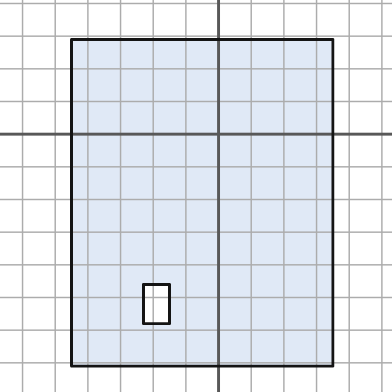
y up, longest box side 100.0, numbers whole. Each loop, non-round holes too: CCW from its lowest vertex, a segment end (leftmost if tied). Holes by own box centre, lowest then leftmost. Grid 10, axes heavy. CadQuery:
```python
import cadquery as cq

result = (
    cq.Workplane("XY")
    .moveTo(-45.0, -71.0)
    .lineTo(35.0, -71.0)
    .lineTo(35.0, 29.0)
    .lineTo(-45.0, 29.0)
    .close()
    .moveTo(-23.0, -58.0)
    .lineTo(-15.0, -58.0)
    .lineTo(-15.0, -46.0)
    .lineTo(-23.0, -46.0)
    .close()
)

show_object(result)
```